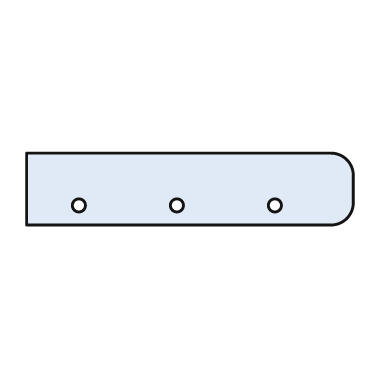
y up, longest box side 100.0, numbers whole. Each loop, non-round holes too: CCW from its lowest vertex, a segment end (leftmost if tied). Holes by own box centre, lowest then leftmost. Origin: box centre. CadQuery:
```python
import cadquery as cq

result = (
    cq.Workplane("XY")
    .moveTo(-50.0, -11.0)
    .lineTo(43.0, -11.0)
    .threePointArc((48.0, -9.0), (50.0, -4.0))
    .lineTo(50.0, 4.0)
    .threePointArc((48.0, 9.0), (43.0, 11.0))
    .lineTo(-50.0, 11.0)
    .close()
    .moveTo(-34.0, -5.0)
    .circle(2.0)
    .moveTo(-4.0, -5.0)
    .circle(2.0)
    .moveTo(26.0, -5.0)
    .circle(2.0)
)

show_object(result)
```